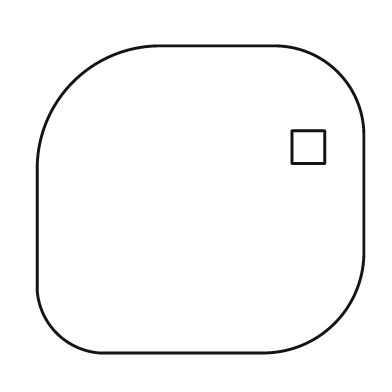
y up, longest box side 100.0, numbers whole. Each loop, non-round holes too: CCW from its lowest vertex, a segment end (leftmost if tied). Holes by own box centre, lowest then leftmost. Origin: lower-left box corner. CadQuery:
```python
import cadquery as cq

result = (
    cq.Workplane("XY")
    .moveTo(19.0, 0.0)
    .lineTo(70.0, 0.0)
    .threePointArc((91.0, 9.0), (100.0, 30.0))
    .lineTo(100.0, 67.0)
    .threePointArc((92.0, 86.0), (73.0, 94.0))
    .lineTo(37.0, 94.0)
    .threePointArc((11.0, 83.0), (0.0, 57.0))
    .lineTo(0.0, 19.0)
    .threePointArc((6.0, 6.0), (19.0, 0.0))
    .close()
    .moveTo(78.0, 58.0)
    .lineTo(88.0, 58.0)
    .lineTo(88.0, 68.0)
    .lineTo(78.0, 68.0)
    .close()
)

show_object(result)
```